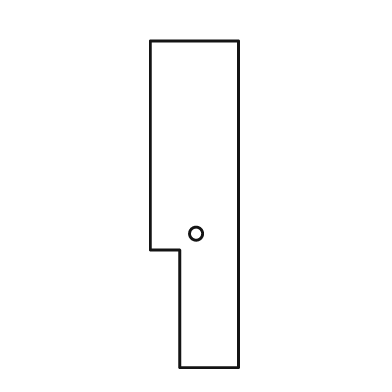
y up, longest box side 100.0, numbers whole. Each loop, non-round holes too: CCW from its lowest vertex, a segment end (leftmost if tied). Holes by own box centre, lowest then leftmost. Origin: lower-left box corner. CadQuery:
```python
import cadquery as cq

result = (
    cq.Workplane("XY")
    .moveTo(9.0, 0.0)
    .lineTo(27.0, 0.0)
    .lineTo(27.0, 100.0)
    .lineTo(0.0, 100.0)
    .lineTo(0.0, 36.0)
    .lineTo(9.0, 36.0)
    .close()
    .moveTo(14.0, 41.0)
    .circle(2.0)
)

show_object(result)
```